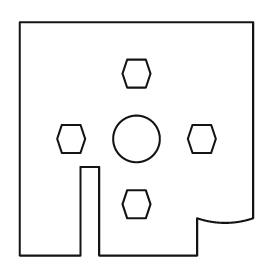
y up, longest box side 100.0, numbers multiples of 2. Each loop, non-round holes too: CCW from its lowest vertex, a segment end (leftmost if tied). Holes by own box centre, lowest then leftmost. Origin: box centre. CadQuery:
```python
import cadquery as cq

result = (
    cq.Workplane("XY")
    .moveTo(-50.0, -50.0)
    .lineTo(-24.0, -50.0)
    .lineTo(-24.0, -12.0)
    .lineTo(-16.0, -12.0)
    .lineTo(-16.0, -50.0)
    .lineTo(26.0, -50.0)
    .lineTo(26.0, -34.0)
    .threePointArc((38.0, -36.0), (50.0, -34.0))
    .lineTo(50.0, 50.0)
    .lineTo(-50.0, 50.0)
    .close()
    .moveTo(-4.0, -34.0)
    .lineTo(4.0, -34.0)
    .lineTo(6.0, -28.0)
    .lineTo(4.0, -22.0)
    .lineTo(-4.0, -22.0)
    .lineTo(-6.0, -28.0)
    .close()
    .moveTo(-32.0, -6.0)
    .lineTo(-24.0, -6.0)
    .lineTo(-22.0, 0.0)
    .lineTo(-24.0, 6.0)
    .lineTo(-32.0, 6.0)
    .lineTo(-34.0, 0.0)
    .close()
    .moveTo(0.0, 0.0)
    .circle(10.0)
    .moveTo(24.0, -6.0)
    .lineTo(32.0, -6.0)
    .lineTo(34.0, 0.0)
    .lineTo(32.0, 6.0)
    .lineTo(24.0, 6.0)
    .lineTo(22.0, 0.0)
    .close()
    .moveTo(-4.0, 22.0)
    .lineTo(4.0, 22.0)
    .lineTo(6.0, 28.0)
    .lineTo(4.0, 34.0)
    .lineTo(-4.0, 34.0)
    .lineTo(-6.0, 28.0)
    .close()
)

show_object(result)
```